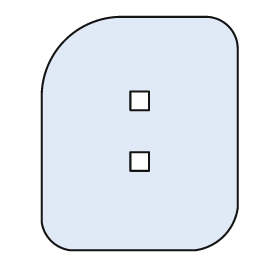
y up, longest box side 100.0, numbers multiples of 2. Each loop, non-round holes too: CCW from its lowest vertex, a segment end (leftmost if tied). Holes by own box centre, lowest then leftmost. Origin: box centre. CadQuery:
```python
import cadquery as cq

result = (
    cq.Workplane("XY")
    .moveTo(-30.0, -50.0)
    .lineTo(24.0, -50.0)
    .threePointArc((36.0, -44.0), (42.0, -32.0))
    .lineTo(42.0, 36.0)
    .threePointArc((38.0, 46.0), (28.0, 50.0))
    .lineTo(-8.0, 50.0)
    .threePointArc((-32.0, 40.0), (-42.0, 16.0))
    .lineTo(-42.0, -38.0)
    .threePointArc((-38.0, -46.0), (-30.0, -50.0))
    .close()
    .moveTo(-4.0, -16.0)
    .lineTo(4.0, -16.0)
    .lineTo(4.0, -8.0)
    .lineTo(-4.0, -8.0)
    .close()
    .moveTo(-4.0, 10.0)
    .lineTo(4.0, 10.0)
    .lineTo(4.0, 18.0)
    .lineTo(-4.0, 18.0)
    .close()
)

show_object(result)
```